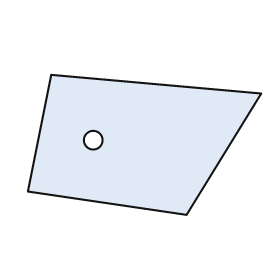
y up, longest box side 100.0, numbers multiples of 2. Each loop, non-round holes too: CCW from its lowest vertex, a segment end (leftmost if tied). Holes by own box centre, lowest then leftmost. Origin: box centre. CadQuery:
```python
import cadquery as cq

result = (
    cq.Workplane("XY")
    .moveTo(18.0, -30.0)
    .lineTo(50.0, 22.0)
    .lineTo(-40.0, 30.0)
    .lineTo(-50.0, -20.0)
    .close()
    .moveTo(-22.0, 2.0)
    .circle(4.0)
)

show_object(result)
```